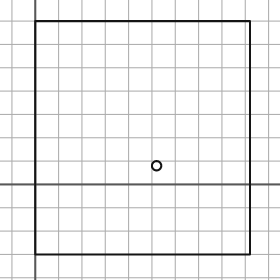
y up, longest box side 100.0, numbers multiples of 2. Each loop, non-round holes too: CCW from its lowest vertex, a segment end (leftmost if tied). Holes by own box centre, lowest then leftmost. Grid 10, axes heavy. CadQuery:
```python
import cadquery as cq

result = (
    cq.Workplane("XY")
    .moveTo(0.0, -30.0)
    .lineTo(92.0, -30.0)
    .lineTo(92.0, 70.0)
    .lineTo(0.0, 70.0)
    .close()
    .moveTo(52.0, 8.0)
    .circle(2.0)
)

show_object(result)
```